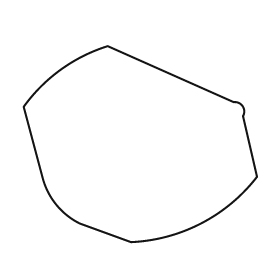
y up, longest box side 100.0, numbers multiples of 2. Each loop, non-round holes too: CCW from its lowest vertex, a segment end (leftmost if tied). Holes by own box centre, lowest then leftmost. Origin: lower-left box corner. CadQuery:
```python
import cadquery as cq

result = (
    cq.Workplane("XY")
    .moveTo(46.0, 0.0)
    .threePointArc((76.0, 8.0), (100.0, 28.0))
    .lineTo(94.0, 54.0)
    .threePointArc((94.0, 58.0), (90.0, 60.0))
    .lineTo(36.0, 84.0)
    .threePointArc((16.0, 74.0), (0.0, 58.0))
    .lineTo(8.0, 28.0)
    .threePointArc((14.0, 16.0), (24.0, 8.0))
    .close()
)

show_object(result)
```